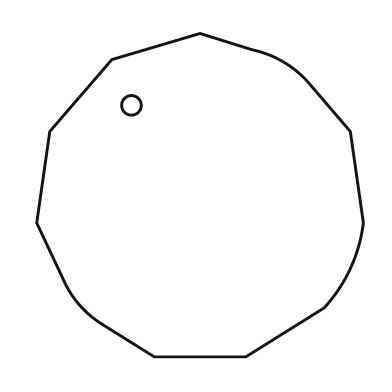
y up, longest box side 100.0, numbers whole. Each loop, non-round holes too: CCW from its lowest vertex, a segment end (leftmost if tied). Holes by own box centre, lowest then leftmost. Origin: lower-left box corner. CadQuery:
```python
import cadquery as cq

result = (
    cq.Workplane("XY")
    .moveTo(36.0, 0.0)
    .lineTo(64.0, 0.0)
    .lineTo(88.0, 15.0)
    .threePointArc((96.0, 27.0), (100.0, 41.0))
    .lineTo(96.0, 69.0)
    .lineTo(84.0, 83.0)
    .threePointArc((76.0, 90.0), (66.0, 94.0))
    .lineTo(50.0, 99.0)
    .lineTo(23.0, 91.0)
    .lineTo(4.0, 69.0)
    .lineTo(0.0, 41.0)
    .lineTo(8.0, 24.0)
    .threePointArc((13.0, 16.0), (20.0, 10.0))
    .close()
    .moveTo(29.0, 77.0)
    .circle(3.0)
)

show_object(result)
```